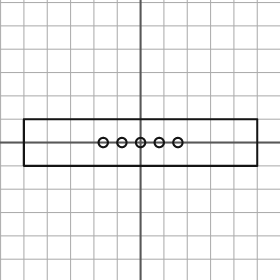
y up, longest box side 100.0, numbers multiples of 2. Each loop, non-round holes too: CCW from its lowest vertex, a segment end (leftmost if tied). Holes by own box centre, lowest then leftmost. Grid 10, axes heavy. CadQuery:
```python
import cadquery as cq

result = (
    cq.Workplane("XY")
    .moveTo(-50.0, -10.0)
    .lineTo(50.0, -10.0)
    .lineTo(50.0, 10.0)
    .lineTo(-50.0, 10.0)
    .close()
    .moveTo(-16.0, 0.0)
    .circle(2.0)
    .moveTo(-8.0, 0.0)
    .circle(2.0)
    .moveTo(0.0, 0.0)
    .circle(2.0)
    .moveTo(8.0, 0.0)
    .circle(2.0)
    .moveTo(16.0, 0.0)
    .circle(2.0)
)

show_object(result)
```